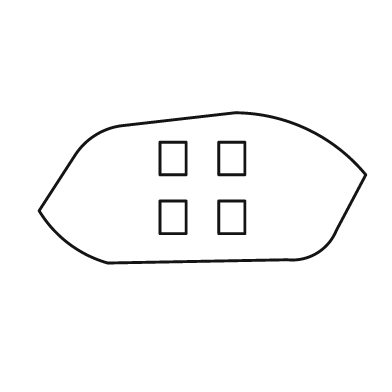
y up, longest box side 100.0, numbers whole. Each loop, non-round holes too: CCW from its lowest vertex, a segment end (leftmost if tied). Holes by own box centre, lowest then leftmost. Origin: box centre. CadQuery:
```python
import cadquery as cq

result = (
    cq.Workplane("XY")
    .moveTo(-29.0, -23.0)
    .lineTo(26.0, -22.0)
    .threePointArc((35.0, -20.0), (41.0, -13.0))
    .lineTo(50.0, 4.0)
    .threePointArc((32.0, 18.0), (10.0, 23.0))
    .lineTo(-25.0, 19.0)
    .threePointArc((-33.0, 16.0), (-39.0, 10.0))
    .lineTo(-50.0, -7.0)
    .threePointArc((-41.0, -17.0), (-29.0, -23.0))
    .close()
    .moveTo(-13.0, -14.0)
    .lineTo(-5.0, -14.0)
    .lineTo(-5.0, -4.0)
    .lineTo(-13.0, -4.0)
    .close()
    .moveTo(5.0, -14.0)
    .lineTo(13.0, -14.0)
    .lineTo(13.0, -4.0)
    .lineTo(5.0, -4.0)
    .close()
    .moveTo(-13.0, 4.0)
    .lineTo(-5.0, 4.0)
    .lineTo(-5.0, 14.0)
    .lineTo(-13.0, 14.0)
    .close()
    .moveTo(5.0, 4.0)
    .lineTo(13.0, 4.0)
    .lineTo(13.0, 14.0)
    .lineTo(5.0, 14.0)
    .close()
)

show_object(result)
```